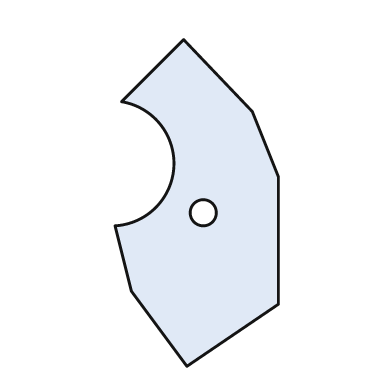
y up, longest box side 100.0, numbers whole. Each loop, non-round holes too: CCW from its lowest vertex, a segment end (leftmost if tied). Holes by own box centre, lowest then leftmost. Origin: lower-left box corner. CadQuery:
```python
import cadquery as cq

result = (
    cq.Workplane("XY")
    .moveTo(22.0, 0.0)
    .lineTo(50.0, 19.0)
    .lineTo(50.0, 58.0)
    .lineTo(42.0, 78.0)
    .lineTo(21.0, 100.0)
    .lineTo(2.0, 81.0)
    .threePointArc((18.0, 61.0), (0.0, 43.0))
    .lineTo(5.0, 23.0)
    .close()
    .moveTo(27.0, 47.0)
    .circle(4.0)
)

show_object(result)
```